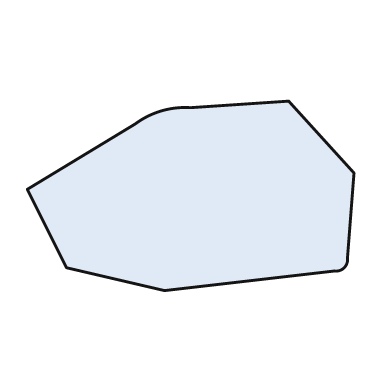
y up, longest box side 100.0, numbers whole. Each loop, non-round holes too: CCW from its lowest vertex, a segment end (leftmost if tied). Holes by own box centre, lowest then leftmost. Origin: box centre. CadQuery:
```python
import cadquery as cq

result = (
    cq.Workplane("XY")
    .moveTo(-8.0, -29.0)
    .lineTo(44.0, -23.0)
    .threePointArc((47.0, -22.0), (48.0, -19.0))
    .lineTo(50.0, 7.0)
    .lineTo(30.0, 29.0)
    .lineTo(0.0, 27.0)
    .threePointArc((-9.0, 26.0), (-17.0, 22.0))
    .lineTo(-50.0, 2.0)
    .lineTo(-38.0, -22.0)
    .close()
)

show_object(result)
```